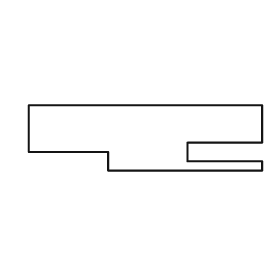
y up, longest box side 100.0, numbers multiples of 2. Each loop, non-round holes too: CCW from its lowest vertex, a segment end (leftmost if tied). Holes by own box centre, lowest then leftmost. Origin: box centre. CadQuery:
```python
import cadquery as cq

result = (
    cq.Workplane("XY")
    .moveTo(-16.0, -14.0)
    .lineTo(50.0, -14.0)
    .lineTo(50.0, -10.0)
    .lineTo(18.0, -10.0)
    .lineTo(18.0, -2.0)
    .lineTo(50.0, -2.0)
    .lineTo(50.0, 14.0)
    .lineTo(-50.0, 14.0)
    .lineTo(-50.0, -6.0)
    .lineTo(-16.0, -6.0)
    .close()
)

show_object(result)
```